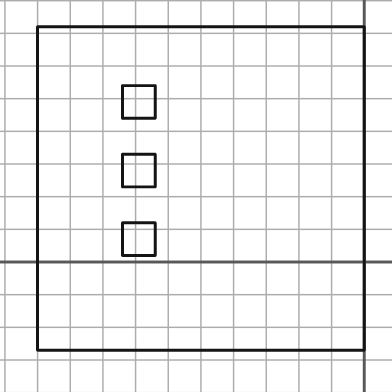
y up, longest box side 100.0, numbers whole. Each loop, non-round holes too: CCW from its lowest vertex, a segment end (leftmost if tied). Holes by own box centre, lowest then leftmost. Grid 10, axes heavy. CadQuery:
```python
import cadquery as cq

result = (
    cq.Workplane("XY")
    .moveTo(-100.0, -27.0)
    .lineTo(0.0, -27.0)
    .lineTo(0.0, 72.0)
    .lineTo(-100.0, 72.0)
    .close()
    .moveTo(-74.0, 2.0)
    .lineTo(-64.0, 2.0)
    .lineTo(-64.0, 12.0)
    .lineTo(-74.0, 12.0)
    .close()
    .moveTo(-74.0, 23.0)
    .lineTo(-64.0, 23.0)
    .lineTo(-64.0, 33.0)
    .lineTo(-74.0, 33.0)
    .close()
    .moveTo(-74.0, 44.0)
    .lineTo(-64.0, 44.0)
    .lineTo(-64.0, 54.0)
    .lineTo(-74.0, 54.0)
    .close()
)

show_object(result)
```